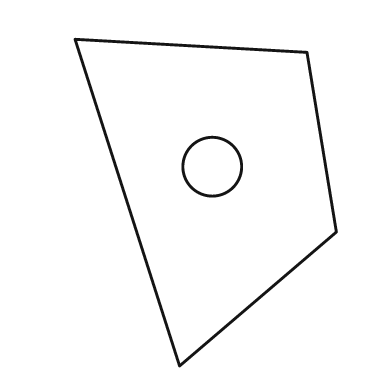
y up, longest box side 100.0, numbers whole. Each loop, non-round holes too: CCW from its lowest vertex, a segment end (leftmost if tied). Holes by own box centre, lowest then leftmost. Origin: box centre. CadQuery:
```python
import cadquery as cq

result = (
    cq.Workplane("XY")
    .moveTo(-8.0, -50.0)
    .lineTo(40.0, -9.0)
    .lineTo(31.0, 46.0)
    .lineTo(-40.0, 50.0)
    .close()
    .moveTo(2.0, 11.0)
    .circle(9.0)
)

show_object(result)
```